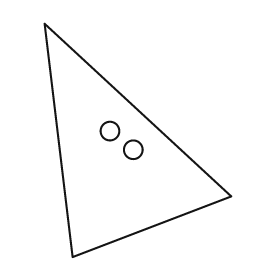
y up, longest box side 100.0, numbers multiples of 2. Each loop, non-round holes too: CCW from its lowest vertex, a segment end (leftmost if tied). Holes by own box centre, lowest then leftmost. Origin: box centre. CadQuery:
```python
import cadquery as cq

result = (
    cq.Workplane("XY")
    .moveTo(-28.0, -50.0)
    .lineTo(40.0, -24.0)
    .lineTo(-40.0, 50.0)
    .close()
    .moveTo(-2.0, -4.0)
    .circle(4.0)
    .moveTo(-12.0, 4.0)
    .circle(4.0)
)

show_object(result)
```